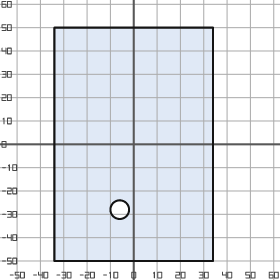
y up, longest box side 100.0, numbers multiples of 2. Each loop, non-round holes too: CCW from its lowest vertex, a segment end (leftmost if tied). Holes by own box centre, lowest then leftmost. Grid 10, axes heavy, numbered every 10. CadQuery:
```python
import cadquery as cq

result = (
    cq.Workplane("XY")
    .moveTo(-34.0, -50.0)
    .lineTo(34.0, -50.0)
    .lineTo(34.0, 50.0)
    .lineTo(-34.0, 50.0)
    .close()
    .moveTo(-6.0, -28.0)
    .circle(4.0)
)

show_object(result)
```